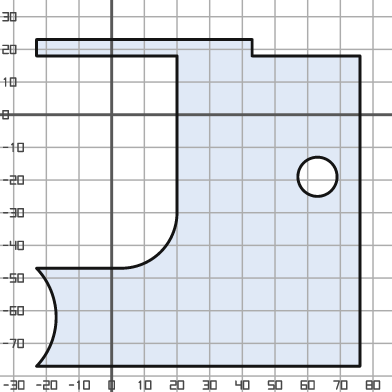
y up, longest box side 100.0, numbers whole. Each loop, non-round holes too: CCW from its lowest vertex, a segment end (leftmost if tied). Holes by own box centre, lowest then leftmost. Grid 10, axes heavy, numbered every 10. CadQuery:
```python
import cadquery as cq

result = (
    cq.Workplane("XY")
    .moveTo(-23.0, -77.0)
    .lineTo(76.0, -77.0)
    .lineTo(76.0, 18.0)
    .lineTo(43.0, 18.0)
    .lineTo(43.0, 23.0)
    .lineTo(-23.0, 23.0)
    .lineTo(-23.0, 18.0)
    .lineTo(20.0, 18.0)
    .lineTo(20.0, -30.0)
    .threePointArc((15.0, -42.0), (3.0, -47.0))
    .lineTo(-23.0, -47.0)
    .threePointArc((-17.0, -62.0), (-23.0, -77.0))
    .close()
    .moveTo(63.0, -19.0)
    .circle(6.0)
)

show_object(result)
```